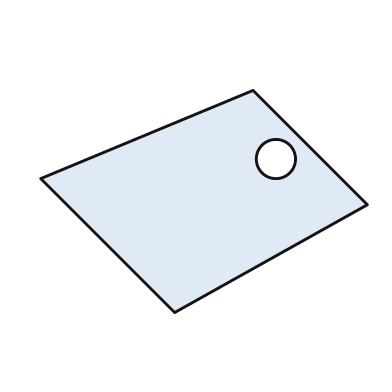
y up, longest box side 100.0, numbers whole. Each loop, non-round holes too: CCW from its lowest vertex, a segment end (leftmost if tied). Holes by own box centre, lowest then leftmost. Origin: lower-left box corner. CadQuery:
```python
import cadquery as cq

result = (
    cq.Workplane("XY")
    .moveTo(41.0, 0.0)
    .lineTo(100.0, 33.0)
    .lineTo(65.0, 68.0)
    .lineTo(0.0, 41.0)
    .close()
    .moveTo(72.0, 47.0)
    .circle(6.0)
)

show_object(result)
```